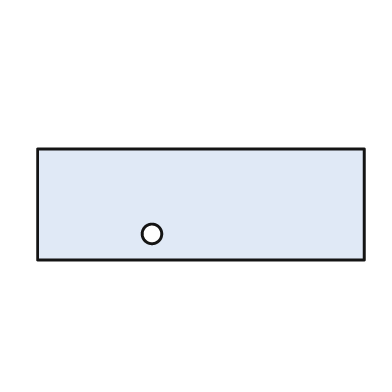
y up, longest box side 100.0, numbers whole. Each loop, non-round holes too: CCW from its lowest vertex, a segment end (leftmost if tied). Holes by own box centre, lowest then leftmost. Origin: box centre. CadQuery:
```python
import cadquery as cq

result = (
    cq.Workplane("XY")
    .moveTo(-50.0, -17.0)
    .lineTo(50.0, -17.0)
    .lineTo(50.0, 17.0)
    .lineTo(-50.0, 17.0)
    .close()
    .moveTo(-15.0, -9.0)
    .circle(3.0)
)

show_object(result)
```